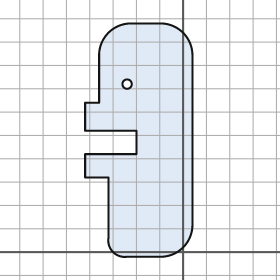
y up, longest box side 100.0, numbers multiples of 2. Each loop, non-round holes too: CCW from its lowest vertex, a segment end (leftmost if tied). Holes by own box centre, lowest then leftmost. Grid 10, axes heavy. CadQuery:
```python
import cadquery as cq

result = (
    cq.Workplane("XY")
    .moveTo(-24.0, -2.0)
    .lineTo(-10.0, -2.0)
    .threePointArc((0.0, 2.0), (4.0, 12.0))
    .lineTo(4.0, 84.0)
    .threePointArc((0.0, 94.0), (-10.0, 98.0))
    .lineTo(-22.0, 98.0)
    .threePointArc((-32.0, 94.0), (-36.0, 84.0))
    .lineTo(-36.0, 64.0)
    .lineTo(-42.0, 64.0)
    .lineTo(-42.0, 52.0)
    .lineTo(-20.0, 52.0)
    .lineTo(-20.0, 42.0)
    .lineTo(-42.0, 42.0)
    .lineTo(-42.0, 32.0)
    .lineTo(-32.0, 32.0)
    .lineTo(-32.0, 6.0)
    .threePointArc((-30.0, 0.0), (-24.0, -2.0))
    .close()
    .moveTo(-24.0, 72.0)
    .circle(2.0)
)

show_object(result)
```